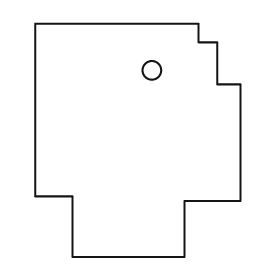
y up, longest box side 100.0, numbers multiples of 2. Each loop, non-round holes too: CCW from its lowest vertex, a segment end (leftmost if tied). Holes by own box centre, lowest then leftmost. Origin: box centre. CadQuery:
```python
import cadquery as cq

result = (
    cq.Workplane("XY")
    .moveTo(-28.0, -50.0)
    .lineTo(20.0, -50.0)
    .lineTo(20.0, -26.0)
    .lineTo(44.0, -26.0)
    .lineTo(44.0, 24.0)
    .lineTo(34.0, 24.0)
    .lineTo(34.0, 42.0)
    .lineTo(26.0, 42.0)
    .lineTo(26.0, 50.0)
    .lineTo(-44.0, 50.0)
    .lineTo(-44.0, -24.0)
    .lineTo(-28.0, -24.0)
    .close()
    .moveTo(6.0, 30.0)
    .circle(4.0)
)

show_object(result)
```